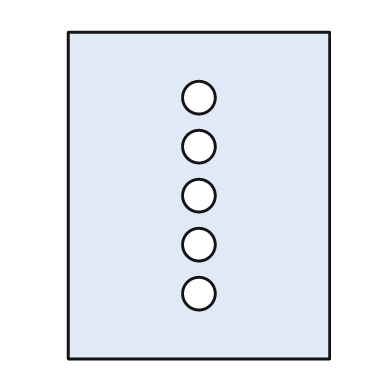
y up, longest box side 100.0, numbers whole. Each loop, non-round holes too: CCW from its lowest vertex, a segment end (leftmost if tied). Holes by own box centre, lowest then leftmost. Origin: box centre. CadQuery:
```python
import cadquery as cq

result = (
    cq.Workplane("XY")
    .moveTo(-40.0, -50.0)
    .lineTo(40.0, -50.0)
    .lineTo(40.0, 50.0)
    .lineTo(-40.0, 50.0)
    .close()
    .moveTo(0.0, -30.0)
    .circle(5.0)
    .moveTo(0.0, -15.0)
    .circle(5.0)
    .moveTo(0.0, 0.0)
    .circle(5.0)
    .moveTo(0.0, 15.0)
    .circle(5.0)
    .moveTo(0.0, 30.0)
    .circle(5.0)
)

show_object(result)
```